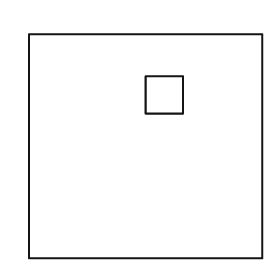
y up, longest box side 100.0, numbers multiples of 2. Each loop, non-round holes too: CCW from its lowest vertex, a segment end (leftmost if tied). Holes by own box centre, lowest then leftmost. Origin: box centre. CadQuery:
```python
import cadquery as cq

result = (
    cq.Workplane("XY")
    .moveTo(-50.0, -48.0)
    .lineTo(50.0, -48.0)
    .lineTo(50.0, 48.0)
    .lineTo(-50.0, 48.0)
    .close()
    .moveTo(0.0, 14.0)
    .lineTo(16.0, 14.0)
    .lineTo(16.0, 30.0)
    .lineTo(0.0, 30.0)
    .close()
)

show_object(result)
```